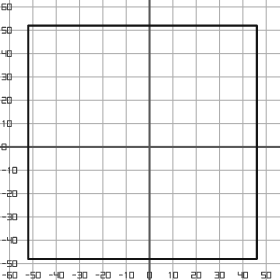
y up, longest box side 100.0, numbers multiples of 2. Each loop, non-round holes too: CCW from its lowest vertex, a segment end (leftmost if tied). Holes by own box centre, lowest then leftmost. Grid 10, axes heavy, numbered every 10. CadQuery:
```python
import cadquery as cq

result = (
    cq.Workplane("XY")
    .moveTo(-52.0, -48.0)
    .lineTo(46.0, -48.0)
    .lineTo(46.0, 52.0)
    .lineTo(-52.0, 52.0)
    .close()
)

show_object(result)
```